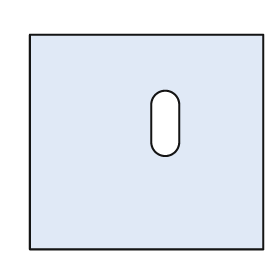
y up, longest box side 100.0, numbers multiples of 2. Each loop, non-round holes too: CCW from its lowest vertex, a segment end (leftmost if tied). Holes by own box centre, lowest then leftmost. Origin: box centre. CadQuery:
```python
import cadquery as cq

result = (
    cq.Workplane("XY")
    .moveTo(-50.0, -46.0)
    .lineTo(50.0, -46.0)
    .lineTo(50.0, 46.0)
    .lineTo(-50.0, 46.0)
    .close()
    .moveTo(2.0, 0.0)
    .threePointArc((8.0, -6.0), (14.0, 0.0))
    .lineTo(14.0, 16.0)
    .threePointArc((8.0, 22.0), (2.0, 16.0))
    .close()
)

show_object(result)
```